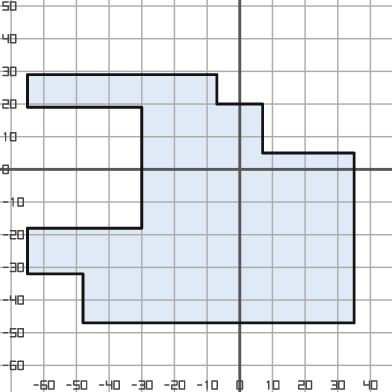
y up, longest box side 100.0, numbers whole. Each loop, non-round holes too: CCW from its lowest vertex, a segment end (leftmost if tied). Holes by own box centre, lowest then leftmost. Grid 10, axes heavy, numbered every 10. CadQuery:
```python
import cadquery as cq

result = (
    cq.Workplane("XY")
    .moveTo(-48.0, -47.0)
    .lineTo(35.0, -47.0)
    .lineTo(35.0, 5.0)
    .lineTo(7.0, 5.0)
    .lineTo(7.0, 20.0)
    .lineTo(-7.0, 20.0)
    .lineTo(-7.0, 29.0)
    .lineTo(-65.0, 29.0)
    .lineTo(-65.0, 19.0)
    .lineTo(-30.0, 19.0)
    .lineTo(-30.0, -18.0)
    .lineTo(-65.0, -18.0)
    .lineTo(-65.0, -32.0)
    .lineTo(-48.0, -32.0)
    .close()
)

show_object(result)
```